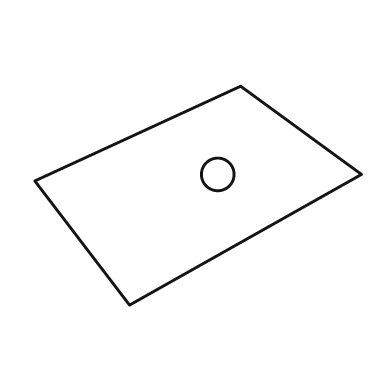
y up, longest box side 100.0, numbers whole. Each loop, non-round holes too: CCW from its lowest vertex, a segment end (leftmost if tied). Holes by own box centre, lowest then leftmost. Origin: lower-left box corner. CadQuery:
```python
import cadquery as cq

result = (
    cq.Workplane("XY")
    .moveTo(29.0, 0.0)
    .lineTo(100.0, 40.0)
    .lineTo(63.0, 67.0)
    .lineTo(0.0, 38.0)
    .close()
    .moveTo(56.0, 40.0)
    .circle(5.0)
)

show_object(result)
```